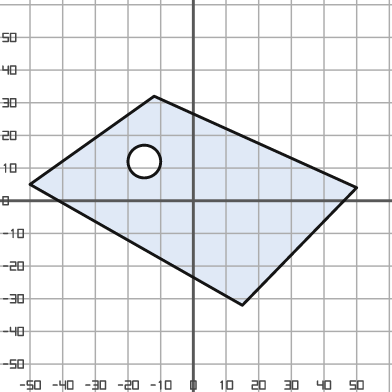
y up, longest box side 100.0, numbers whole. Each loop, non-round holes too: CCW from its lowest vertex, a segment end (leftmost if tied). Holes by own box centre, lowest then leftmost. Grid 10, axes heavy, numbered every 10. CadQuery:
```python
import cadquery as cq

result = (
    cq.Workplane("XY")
    .moveTo(15.0, -32.0)
    .lineTo(50.0, 4.0)
    .lineTo(-12.0, 32.0)
    .lineTo(-50.0, 5.0)
    .close()
    .moveTo(-15.0, 12.0)
    .circle(5.0)
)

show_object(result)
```